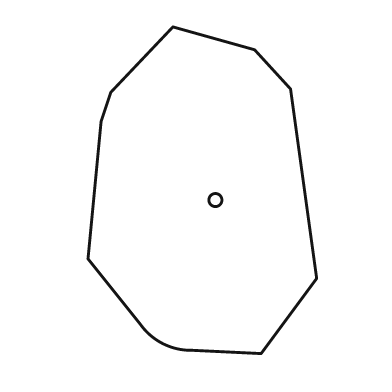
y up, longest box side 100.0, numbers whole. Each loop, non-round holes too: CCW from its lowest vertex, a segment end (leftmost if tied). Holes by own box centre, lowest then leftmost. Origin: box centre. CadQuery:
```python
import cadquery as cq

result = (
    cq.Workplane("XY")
    .moveTo(18.0, -50.0)
    .lineTo(35.0, -27.0)
    .lineTo(27.0, 31.0)
    .lineTo(16.0, 43.0)
    .lineTo(-9.0, 50.0)
    .lineTo(-28.0, 30.0)
    .lineTo(-31.0, 21.0)
    .lineTo(-35.0, -21.0)
    .lineTo(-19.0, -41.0)
    .threePointArc((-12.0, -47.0), (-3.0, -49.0))
    .close()
    .moveTo(4.0, -3.0)
    .circle(2.0)
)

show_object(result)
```